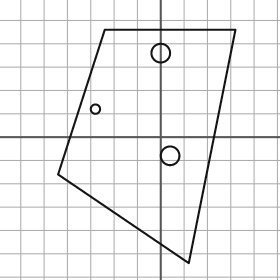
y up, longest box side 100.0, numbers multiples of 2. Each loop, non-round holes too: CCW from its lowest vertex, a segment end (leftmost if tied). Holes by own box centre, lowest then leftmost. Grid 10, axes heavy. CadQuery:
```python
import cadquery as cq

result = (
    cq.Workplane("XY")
    .moveTo(12.0, -54.0)
    .lineTo(32.0, 46.0)
    .lineTo(-24.0, 46.0)
    .lineTo(-44.0, -16.0)
    .close()
    .moveTo(4.0, -8.0)
    .circle(4.0)
    .moveTo(-28.0, 12.0)
    .circle(2.0)
    .moveTo(0.0, 36.0)
    .circle(4.0)
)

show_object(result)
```